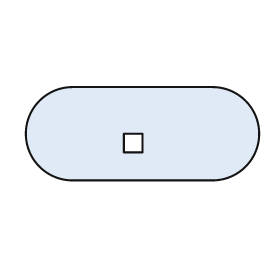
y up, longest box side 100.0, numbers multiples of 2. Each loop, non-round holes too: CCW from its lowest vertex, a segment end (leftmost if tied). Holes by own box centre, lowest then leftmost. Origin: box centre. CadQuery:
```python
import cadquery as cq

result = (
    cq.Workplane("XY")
    .moveTo(-30.0, -20.0)
    .lineTo(30.0, -20.0)
    .threePointArc((50.0, 0.0), (30.0, 20.0))
    .lineTo(-30.0, 20.0)
    .threePointArc((-50.0, 0.0), (-30.0, -20.0))
    .close()
    .moveTo(-8.0, -8.0)
    .lineTo(0.0, -8.0)
    .lineTo(0.0, 0.0)
    .lineTo(-8.0, 0.0)
    .close()
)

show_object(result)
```